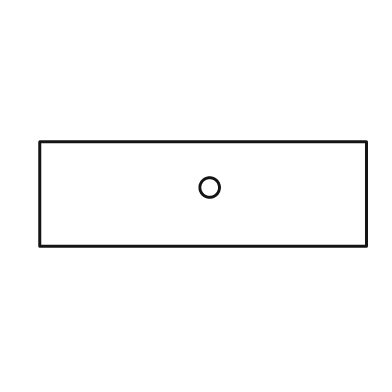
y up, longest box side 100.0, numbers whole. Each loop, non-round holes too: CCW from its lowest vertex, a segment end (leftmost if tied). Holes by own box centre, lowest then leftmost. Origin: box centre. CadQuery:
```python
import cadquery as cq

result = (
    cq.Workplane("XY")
    .moveTo(-50.0, -16.0)
    .lineTo(50.0, -16.0)
    .lineTo(50.0, 16.0)
    .lineTo(-50.0, 16.0)
    .close()
    .moveTo(2.0, 2.0)
    .circle(3.0)
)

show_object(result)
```